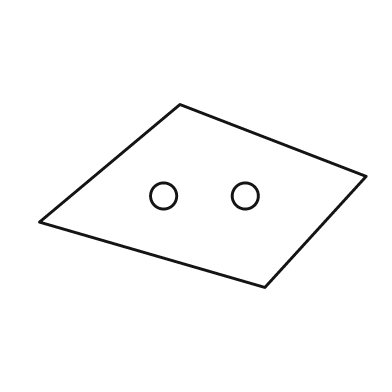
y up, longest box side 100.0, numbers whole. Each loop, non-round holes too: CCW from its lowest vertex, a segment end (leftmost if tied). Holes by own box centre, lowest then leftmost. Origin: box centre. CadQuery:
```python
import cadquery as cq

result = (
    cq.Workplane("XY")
    .moveTo(19.0, -28.0)
    .lineTo(50.0, 6.0)
    .lineTo(-7.0, 28.0)
    .lineTo(-50.0, -8.0)
    .close()
    .moveTo(-12.0, 0.0)
    .circle(4.0)
    .moveTo(13.0, 0.0)
    .circle(4.0)
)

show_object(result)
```